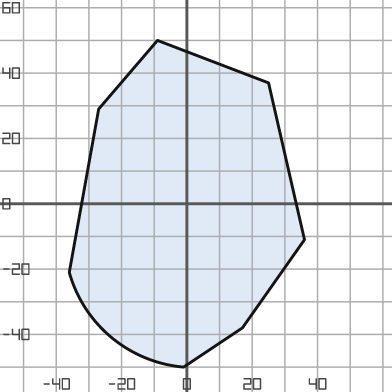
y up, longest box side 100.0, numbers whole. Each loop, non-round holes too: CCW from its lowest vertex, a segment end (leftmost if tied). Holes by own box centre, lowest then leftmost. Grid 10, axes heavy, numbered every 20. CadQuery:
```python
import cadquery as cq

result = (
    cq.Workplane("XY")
    .moveTo(-1.0, -50.0)
    .lineTo(17.0, -38.0)
    .lineTo(36.0, -11.0)
    .lineTo(25.0, 37.0)
    .lineTo(-9.0, 50.0)
    .lineTo(-27.0, 29.0)
    .lineTo(-36.0, -21.0)
    .threePointArc((-23.0, -41.0), (-1.0, -50.0))
    .close()
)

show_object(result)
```